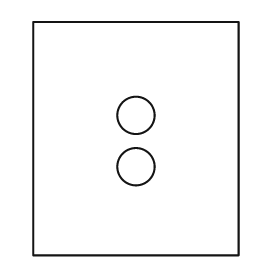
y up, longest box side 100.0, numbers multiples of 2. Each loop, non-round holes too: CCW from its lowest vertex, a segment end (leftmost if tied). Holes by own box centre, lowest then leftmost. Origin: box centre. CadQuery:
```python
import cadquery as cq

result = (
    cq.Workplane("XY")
    .moveTo(-44.0, -50.0)
    .lineTo(44.0, -50.0)
    .lineTo(44.0, 50.0)
    .lineTo(-44.0, 50.0)
    .close()
    .moveTo(0.0, -12.0)
    .circle(8.0)
    .moveTo(0.0, 10.0)
    .circle(8.0)
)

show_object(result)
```